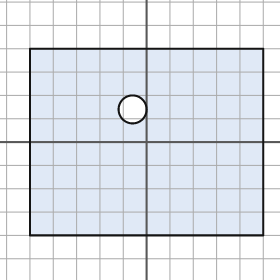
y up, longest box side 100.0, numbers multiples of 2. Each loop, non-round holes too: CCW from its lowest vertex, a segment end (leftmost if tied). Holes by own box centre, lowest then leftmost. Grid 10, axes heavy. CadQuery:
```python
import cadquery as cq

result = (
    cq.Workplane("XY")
    .moveTo(-50.0, -40.0)
    .lineTo(50.0, -40.0)
    .lineTo(50.0, 40.0)
    .lineTo(-50.0, 40.0)
    .close()
    .moveTo(-6.0, 14.0)
    .circle(6.0)
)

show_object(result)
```